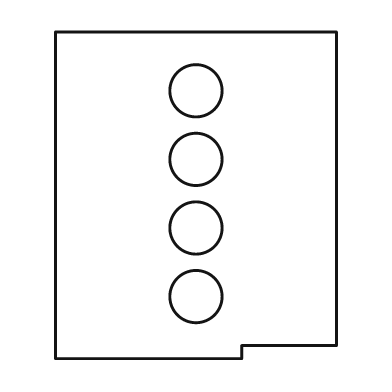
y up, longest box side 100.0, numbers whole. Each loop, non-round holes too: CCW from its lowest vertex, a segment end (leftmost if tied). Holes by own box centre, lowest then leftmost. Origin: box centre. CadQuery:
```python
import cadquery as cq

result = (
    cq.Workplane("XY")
    .moveTo(-43.0, -50.0)
    .lineTo(14.0, -50.0)
    .lineTo(14.0, -46.0)
    .lineTo(43.0, -46.0)
    .lineTo(43.0, 50.0)
    .lineTo(-43.0, 50.0)
    .close()
    .moveTo(0.0, -31.0)
    .circle(8.0)
    .moveTo(0.0, -10.0)
    .circle(8.0)
    .moveTo(0.0, 11.0)
    .circle(8.0)
    .moveTo(0.0, 32.0)
    .circle(8.0)
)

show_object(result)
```